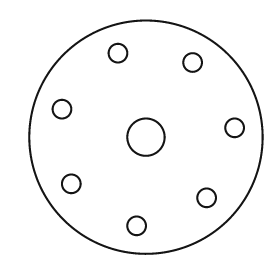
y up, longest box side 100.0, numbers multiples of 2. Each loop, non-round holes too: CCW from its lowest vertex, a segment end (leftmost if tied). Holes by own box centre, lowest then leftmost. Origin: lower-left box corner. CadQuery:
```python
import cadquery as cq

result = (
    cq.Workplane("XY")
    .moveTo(50.0, 50.0)
    .circle(50.0)
    .moveTo(46.0, 12.0)
    .circle(4.0)
    .moveTo(76.0, 24.0)
    .circle(4.0)
    .moveTo(18.0, 30.0)
    .circle(4.0)
    .moveTo(50.0, 50.0)
    .circle(8.0)
    .moveTo(88.0, 54.0)
    .circle(4.0)
    .moveTo(14.0, 62.0)
    .circle(4.0)
    .moveTo(70.0, 82.0)
    .circle(4.0)
    .moveTo(38.0, 86.0)
    .circle(4.0)
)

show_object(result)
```